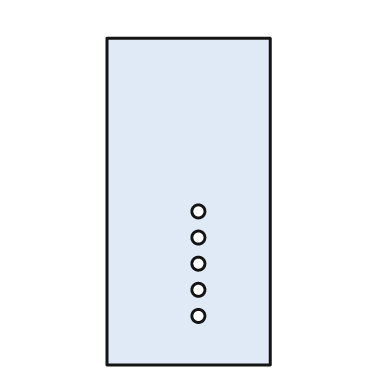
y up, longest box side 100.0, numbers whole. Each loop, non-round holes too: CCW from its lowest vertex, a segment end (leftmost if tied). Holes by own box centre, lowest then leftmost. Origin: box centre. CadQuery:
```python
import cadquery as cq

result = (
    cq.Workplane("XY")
    .moveTo(-25.0, -50.0)
    .lineTo(25.0, -50.0)
    .lineTo(25.0, 50.0)
    .lineTo(-25.0, 50.0)
    .close()
    .moveTo(3.0, -35.0)
    .circle(2.0)
    .moveTo(3.0, -27.0)
    .circle(2.0)
    .moveTo(3.0, -19.0)
    .circle(2.0)
    .moveTo(3.0, -11.0)
    .circle(2.0)
    .moveTo(3.0, -3.0)
    .circle(2.0)
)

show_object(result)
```